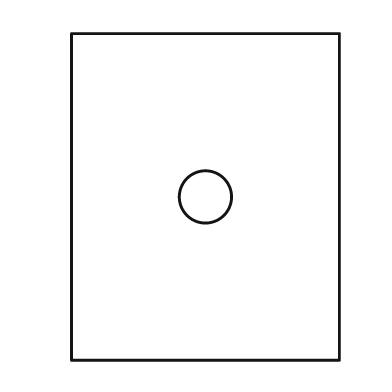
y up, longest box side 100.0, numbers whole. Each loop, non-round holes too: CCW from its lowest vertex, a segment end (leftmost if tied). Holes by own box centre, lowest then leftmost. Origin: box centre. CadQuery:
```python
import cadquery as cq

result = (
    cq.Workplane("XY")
    .moveTo(-41.0, -50.0)
    .lineTo(41.0, -50.0)
    .lineTo(41.0, 50.0)
    .lineTo(-41.0, 50.0)
    .close()
    .moveTo(0.0, 0.0)
    .circle(8.0)
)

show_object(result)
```